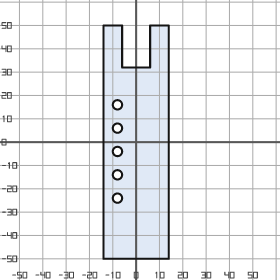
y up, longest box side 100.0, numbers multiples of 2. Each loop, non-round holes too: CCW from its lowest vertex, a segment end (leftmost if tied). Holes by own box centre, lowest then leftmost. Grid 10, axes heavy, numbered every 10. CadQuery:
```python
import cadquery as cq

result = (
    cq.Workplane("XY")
    .moveTo(-14.0, -50.0)
    .lineTo(14.0, -50.0)
    .lineTo(14.0, 50.0)
    .lineTo(6.0, 50.0)
    .lineTo(6.0, 32.0)
    .lineTo(-6.0, 32.0)
    .lineTo(-6.0, 50.0)
    .lineTo(-14.0, 50.0)
    .close()
    .moveTo(-8.0, -24.0)
    .circle(2.0)
    .moveTo(-8.0, -14.0)
    .circle(2.0)
    .moveTo(-8.0, -4.0)
    .circle(2.0)
    .moveTo(-8.0, 6.0)
    .circle(2.0)
    .moveTo(-8.0, 16.0)
    .circle(2.0)
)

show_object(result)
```